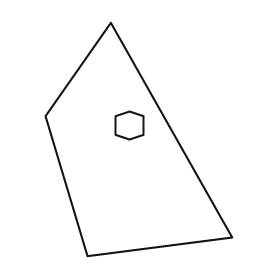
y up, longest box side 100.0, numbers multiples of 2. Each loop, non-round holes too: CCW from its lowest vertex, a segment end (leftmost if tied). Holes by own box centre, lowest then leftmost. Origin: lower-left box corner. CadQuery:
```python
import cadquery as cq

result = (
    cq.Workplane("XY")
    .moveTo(18.0, 0.0)
    .lineTo(80.0, 8.0)
    .lineTo(28.0, 100.0)
    .lineTo(0.0, 60.0)
    .close()
    .moveTo(36.0, 50.0)
    .lineTo(42.0, 52.0)
    .lineTo(42.0, 60.0)
    .lineTo(36.0, 62.0)
    .lineTo(30.0, 60.0)
    .lineTo(30.0, 52.0)
    .close()
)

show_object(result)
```